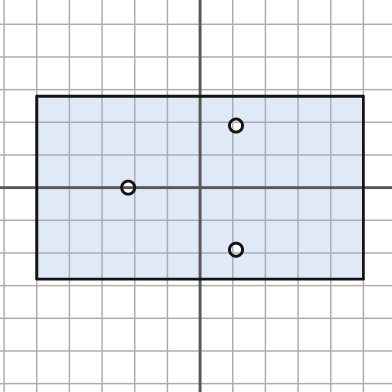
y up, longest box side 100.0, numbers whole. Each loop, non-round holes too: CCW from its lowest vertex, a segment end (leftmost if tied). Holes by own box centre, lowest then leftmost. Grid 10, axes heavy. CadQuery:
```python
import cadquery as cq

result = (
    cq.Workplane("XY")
    .moveTo(-50.0, -28.0)
    .lineTo(50.0, -28.0)
    .lineTo(50.0, 28.0)
    .lineTo(-50.0, 28.0)
    .close()
    .moveTo(11.0, -19.0)
    .circle(2.0)
    .moveTo(-22.0, 0.0)
    .circle(2.0)
    .moveTo(11.0, 19.0)
    .circle(2.0)
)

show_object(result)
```